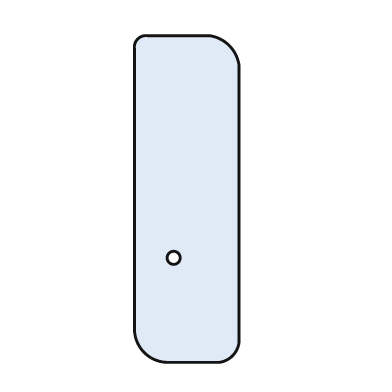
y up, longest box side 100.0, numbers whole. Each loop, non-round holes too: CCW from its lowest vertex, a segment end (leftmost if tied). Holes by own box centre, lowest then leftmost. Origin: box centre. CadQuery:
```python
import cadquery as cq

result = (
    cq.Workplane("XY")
    .moveTo(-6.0, -50.0)
    .lineTo(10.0, -50.0)
    .threePointArc((14.0, -48.0), (16.0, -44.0))
    .lineTo(16.0, 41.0)
    .threePointArc((13.0, 47.0), (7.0, 50.0))
    .lineTo(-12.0, 50.0)
    .threePointArc((-15.0, 49.0), (-16.0, 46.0))
    .lineTo(-16.0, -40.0)
    .threePointArc((-13.0, -47.0), (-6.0, -50.0))
    .close()
    .moveTo(-4.0, -18.0)
    .circle(2.0)
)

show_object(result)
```